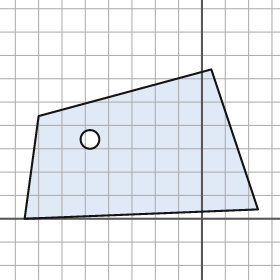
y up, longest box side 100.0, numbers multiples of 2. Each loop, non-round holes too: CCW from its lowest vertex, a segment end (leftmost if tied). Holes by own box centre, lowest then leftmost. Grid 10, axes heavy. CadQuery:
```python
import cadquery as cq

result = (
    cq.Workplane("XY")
    .moveTo(-76.0, 0.0)
    .lineTo(24.0, 4.0)
    .lineTo(4.0, 64.0)
    .lineTo(-70.0, 44.0)
    .close()
    .moveTo(-48.0, 34.0)
    .circle(4.0)
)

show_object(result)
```